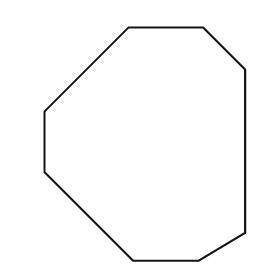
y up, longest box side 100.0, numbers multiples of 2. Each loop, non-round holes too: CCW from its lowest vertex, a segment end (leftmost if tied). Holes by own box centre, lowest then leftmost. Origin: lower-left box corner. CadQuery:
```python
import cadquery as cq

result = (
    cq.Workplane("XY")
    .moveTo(38.0, 0.0)
    .lineTo(66.0, 0.0)
    .lineTo(86.0, 12.0)
    .lineTo(86.0, 82.0)
    .lineTo(68.0, 100.0)
    .lineTo(36.0, 100.0)
    .lineTo(0.0, 64.0)
    .lineTo(0.0, 38.0)
    .close()
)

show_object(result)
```